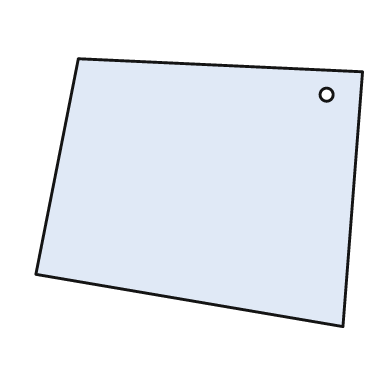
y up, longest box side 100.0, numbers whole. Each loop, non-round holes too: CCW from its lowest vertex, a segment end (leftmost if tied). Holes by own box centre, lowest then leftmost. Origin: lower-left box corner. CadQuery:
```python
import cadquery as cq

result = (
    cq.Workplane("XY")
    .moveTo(94.0, 0.0)
    .lineTo(100.0, 78.0)
    .lineTo(13.0, 82.0)
    .lineTo(0.0, 16.0)
    .close()
    .moveTo(89.0, 71.0)
    .circle(2.0)
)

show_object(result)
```